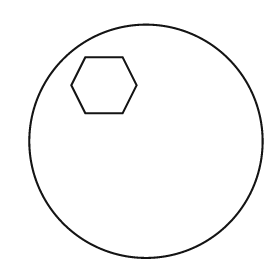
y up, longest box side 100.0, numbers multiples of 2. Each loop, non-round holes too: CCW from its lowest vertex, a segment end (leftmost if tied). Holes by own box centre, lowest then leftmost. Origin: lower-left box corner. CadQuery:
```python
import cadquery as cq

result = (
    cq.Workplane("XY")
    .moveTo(50.0, 50.0)
    .circle(50.0)
    .moveTo(24.0, 62.0)
    .lineTo(40.0, 62.0)
    .lineTo(46.0, 74.0)
    .lineTo(40.0, 86.0)
    .lineTo(24.0, 86.0)
    .lineTo(18.0, 74.0)
    .close()
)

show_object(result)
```